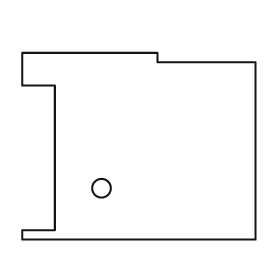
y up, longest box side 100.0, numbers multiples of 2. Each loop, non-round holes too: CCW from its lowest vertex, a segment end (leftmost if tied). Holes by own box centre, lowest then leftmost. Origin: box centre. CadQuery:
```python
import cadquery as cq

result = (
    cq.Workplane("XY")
    .moveTo(-50.0, -40.0)
    .lineTo(50.0, -40.0)
    .lineTo(50.0, 36.0)
    .lineTo(8.0, 36.0)
    .lineTo(8.0, 40.0)
    .lineTo(-50.0, 40.0)
    .lineTo(-50.0, 26.0)
    .lineTo(-36.0, 26.0)
    .lineTo(-36.0, -36.0)
    .lineTo(-50.0, -36.0)
    .close()
    .moveTo(-16.0, -18.0)
    .circle(4.0)
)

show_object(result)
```